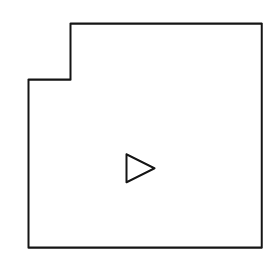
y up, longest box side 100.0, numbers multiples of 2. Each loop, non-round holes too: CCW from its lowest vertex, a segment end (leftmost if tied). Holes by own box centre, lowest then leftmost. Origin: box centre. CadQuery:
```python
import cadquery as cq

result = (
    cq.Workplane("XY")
    .moveTo(-50.0, -48.0)
    .lineTo(50.0, -48.0)
    .lineTo(50.0, 48.0)
    .lineTo(-32.0, 48.0)
    .lineTo(-32.0, 24.0)
    .lineTo(-50.0, 24.0)
    .close()
    .moveTo(-8.0, -20.0)
    .lineTo(4.0, -14.0)
    .lineTo(-8.0, -8.0)
    .close()
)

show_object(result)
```